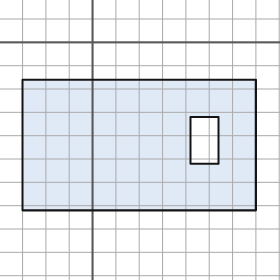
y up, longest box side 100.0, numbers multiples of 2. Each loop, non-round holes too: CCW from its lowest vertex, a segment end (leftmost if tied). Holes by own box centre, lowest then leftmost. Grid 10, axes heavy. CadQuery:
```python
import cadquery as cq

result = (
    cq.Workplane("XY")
    .moveTo(-30.0, -72.0)
    .lineTo(70.0, -72.0)
    .lineTo(70.0, -16.0)
    .lineTo(-30.0, -16.0)
    .close()
    .moveTo(42.0, -52.0)
    .lineTo(54.0, -52.0)
    .lineTo(54.0, -32.0)
    .lineTo(42.0, -32.0)
    .close()
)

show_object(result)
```